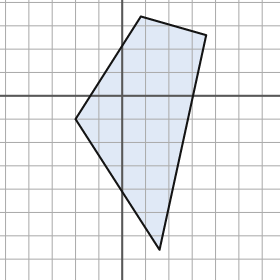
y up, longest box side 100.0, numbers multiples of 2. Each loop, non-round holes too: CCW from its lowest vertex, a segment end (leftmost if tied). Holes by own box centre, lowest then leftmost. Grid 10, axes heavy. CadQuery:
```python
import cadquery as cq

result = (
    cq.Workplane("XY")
    .moveTo(16.0, -66.0)
    .lineTo(36.0, 26.0)
    .lineTo(8.0, 34.0)
    .lineTo(-20.0, -10.0)
    .close()
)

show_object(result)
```